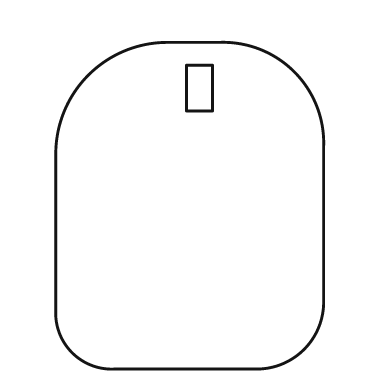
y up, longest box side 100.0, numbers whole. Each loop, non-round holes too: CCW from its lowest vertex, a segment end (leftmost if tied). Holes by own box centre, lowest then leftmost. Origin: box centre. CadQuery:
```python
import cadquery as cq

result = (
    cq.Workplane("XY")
    .moveTo(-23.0, -50.0)
    .lineTo(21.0, -50.0)
    .threePointArc((35.0, -44.0), (41.0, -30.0))
    .lineTo(41.0, 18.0)
    .threePointArc((32.0, 41.0), (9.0, 50.0))
    .lineTo(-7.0, 50.0)
    .threePointArc((-31.0, 40.0), (-41.0, 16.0))
    .lineTo(-41.0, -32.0)
    .threePointArc((-36.0, -45.0), (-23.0, -50.0))
    .close()
    .moveTo(-1.0, 29.0)
    .lineTo(7.0, 29.0)
    .lineTo(7.0, 43.0)
    .lineTo(-1.0, 43.0)
    .close()
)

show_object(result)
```